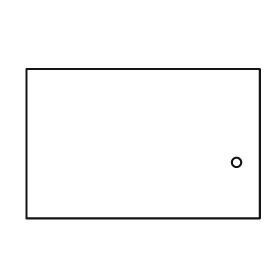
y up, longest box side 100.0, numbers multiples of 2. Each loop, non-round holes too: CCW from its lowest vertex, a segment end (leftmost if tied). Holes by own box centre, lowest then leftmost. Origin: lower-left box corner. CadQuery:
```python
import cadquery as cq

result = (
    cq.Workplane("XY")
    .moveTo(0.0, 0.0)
    .lineTo(100.0, 0.0)
    .lineTo(100.0, 64.0)
    .lineTo(0.0, 64.0)
    .close()
    .moveTo(90.0, 24.0)
    .circle(2.0)
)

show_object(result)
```